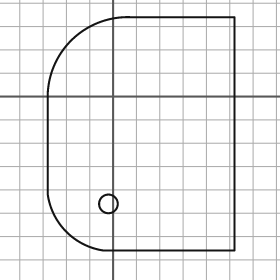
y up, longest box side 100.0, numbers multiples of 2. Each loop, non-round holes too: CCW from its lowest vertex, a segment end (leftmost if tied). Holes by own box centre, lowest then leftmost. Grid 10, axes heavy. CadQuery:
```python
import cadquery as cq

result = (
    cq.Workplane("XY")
    .moveTo(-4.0, -66.0)
    .lineTo(52.0, -66.0)
    .lineTo(52.0, 34.0)
    .lineTo(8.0, 34.0)
    .threePointArc((-18.0, 24.0), (-28.0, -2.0))
    .lineTo(-28.0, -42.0)
    .threePointArc((-20.0, -58.0), (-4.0, -66.0))
    .close()
    .moveTo(-2.0, -46.0)
    .circle(4.0)
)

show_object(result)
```